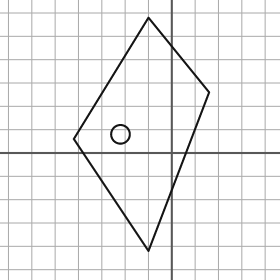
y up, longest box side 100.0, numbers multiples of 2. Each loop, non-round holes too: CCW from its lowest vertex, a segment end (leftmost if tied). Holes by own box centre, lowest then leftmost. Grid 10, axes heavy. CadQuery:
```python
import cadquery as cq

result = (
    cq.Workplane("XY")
    .moveTo(-10.0, -42.0)
    .lineTo(16.0, 26.0)
    .lineTo(-10.0, 58.0)
    .lineTo(-42.0, 6.0)
    .close()
    .moveTo(-22.0, 8.0)
    .circle(4.0)
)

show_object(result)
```